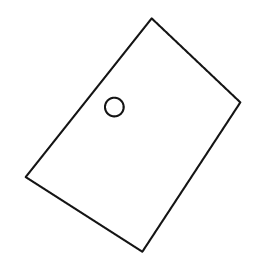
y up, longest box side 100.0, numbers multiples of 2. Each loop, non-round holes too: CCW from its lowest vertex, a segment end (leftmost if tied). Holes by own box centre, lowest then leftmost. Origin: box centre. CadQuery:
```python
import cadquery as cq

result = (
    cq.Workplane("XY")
    .moveTo(4.0, -50.0)
    .lineTo(46.0, 14.0)
    .lineTo(8.0, 50.0)
    .lineTo(-46.0, -18.0)
    .close()
    .moveTo(-8.0, 12.0)
    .circle(4.0)
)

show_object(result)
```